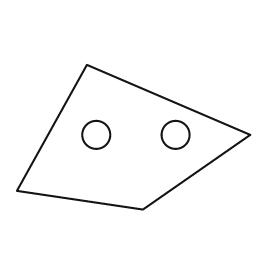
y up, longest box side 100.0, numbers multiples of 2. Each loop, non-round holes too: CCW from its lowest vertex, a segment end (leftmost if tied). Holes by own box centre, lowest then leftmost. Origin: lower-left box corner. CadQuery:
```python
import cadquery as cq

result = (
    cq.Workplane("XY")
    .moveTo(54.0, 0.0)
    .lineTo(100.0, 32.0)
    .lineTo(30.0, 62.0)
    .lineTo(0.0, 8.0)
    .close()
    .moveTo(34.0, 32.0)
    .circle(6.0)
    .moveTo(68.0, 32.0)
    .circle(6.0)
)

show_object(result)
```